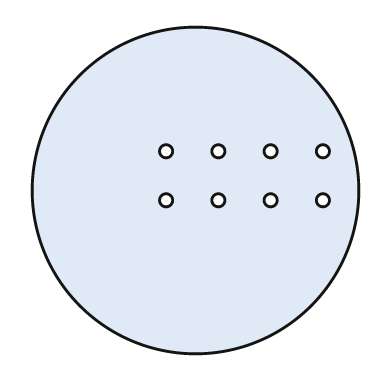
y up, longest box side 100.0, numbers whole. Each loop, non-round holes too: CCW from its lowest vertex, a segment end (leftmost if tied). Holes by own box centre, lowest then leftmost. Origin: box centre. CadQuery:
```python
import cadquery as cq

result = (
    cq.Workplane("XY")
    .moveTo(0.0, 0.0)
    .circle(50.0)
    .moveTo(-9.0, -3.0)
    .circle(2.0)
    .moveTo(7.0, -3.0)
    .circle(2.0)
    .moveTo(23.0, -3.0)
    .circle(2.0)
    .moveTo(39.0, -3.0)
    .circle(2.0)
    .moveTo(-9.0, 12.0)
    .circle(2.0)
    .moveTo(7.0, 12.0)
    .circle(2.0)
    .moveTo(23.0, 12.0)
    .circle(2.0)
    .moveTo(39.0, 12.0)
    .circle(2.0)
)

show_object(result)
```